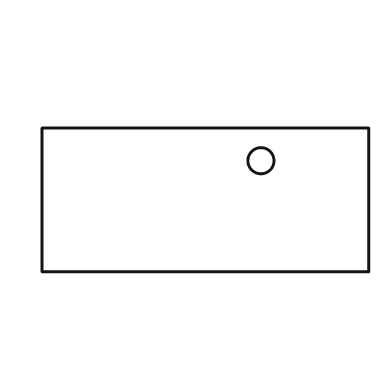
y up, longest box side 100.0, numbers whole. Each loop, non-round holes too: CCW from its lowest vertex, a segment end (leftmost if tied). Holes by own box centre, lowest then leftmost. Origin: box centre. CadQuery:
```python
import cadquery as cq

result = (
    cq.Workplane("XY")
    .moveTo(-50.0, -22.0)
    .lineTo(50.0, -22.0)
    .lineTo(50.0, 22.0)
    .lineTo(-50.0, 22.0)
    .close()
    .moveTo(17.0, 12.0)
    .circle(4.0)
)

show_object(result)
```